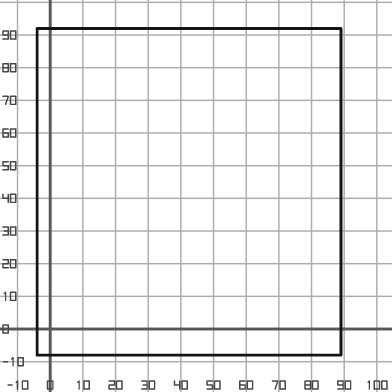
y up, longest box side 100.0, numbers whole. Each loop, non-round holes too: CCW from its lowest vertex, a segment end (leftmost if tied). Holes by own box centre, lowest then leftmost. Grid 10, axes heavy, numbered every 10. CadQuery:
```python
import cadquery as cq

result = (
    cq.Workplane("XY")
    .moveTo(-4.0, -8.0)
    .lineTo(89.0, -8.0)
    .lineTo(89.0, 92.0)
    .lineTo(-4.0, 92.0)
    .close()
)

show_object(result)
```